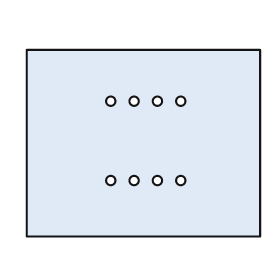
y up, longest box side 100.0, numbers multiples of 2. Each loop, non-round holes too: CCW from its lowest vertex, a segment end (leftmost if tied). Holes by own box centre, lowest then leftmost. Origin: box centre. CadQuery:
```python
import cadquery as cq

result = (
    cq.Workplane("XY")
    .moveTo(-50.0, -40.0)
    .lineTo(50.0, -40.0)
    .lineTo(50.0, 40.0)
    .lineTo(-50.0, 40.0)
    .close()
    .moveTo(-14.0, -16.0)
    .circle(2.0)
    .moveTo(-4.0, -16.0)
    .circle(2.0)
    .moveTo(6.0, -16.0)
    .circle(2.0)
    .moveTo(16.0, -16.0)
    .circle(2.0)
    .moveTo(-14.0, 18.0)
    .circle(2.0)
    .moveTo(-4.0, 18.0)
    .circle(2.0)
    .moveTo(6.0, 18.0)
    .circle(2.0)
    .moveTo(16.0, 18.0)
    .circle(2.0)
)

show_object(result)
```